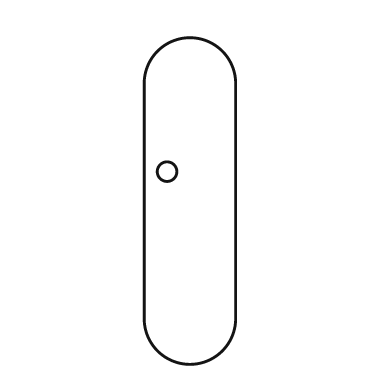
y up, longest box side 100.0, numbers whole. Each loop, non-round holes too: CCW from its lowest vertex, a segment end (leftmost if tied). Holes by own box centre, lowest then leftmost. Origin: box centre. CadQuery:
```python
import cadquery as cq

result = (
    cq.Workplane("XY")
    .moveTo(-14.0, -36.0)
    .threePointArc((0.0, -50.0), (14.0, -36.0))
    .lineTo(14.0, 36.0)
    .threePointArc((0.0, 50.0), (-14.0, 36.0))
    .close()
    .moveTo(-7.0, 9.0)
    .circle(3.0)
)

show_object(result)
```